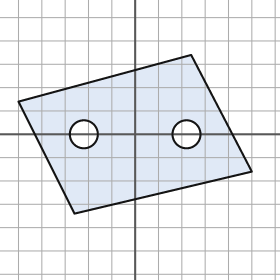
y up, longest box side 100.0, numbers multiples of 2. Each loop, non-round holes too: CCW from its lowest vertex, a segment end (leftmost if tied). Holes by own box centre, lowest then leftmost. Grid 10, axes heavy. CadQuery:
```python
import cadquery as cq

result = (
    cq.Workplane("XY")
    .moveTo(-26.0, -34.0)
    .lineTo(50.0, -16.0)
    .lineTo(24.0, 34.0)
    .lineTo(-50.0, 14.0)
    .close()
    .moveTo(-22.0, 0.0)
    .circle(6.0)
    .moveTo(22.0, 0.0)
    .circle(6.0)
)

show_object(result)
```